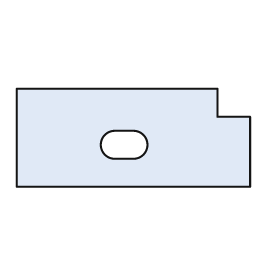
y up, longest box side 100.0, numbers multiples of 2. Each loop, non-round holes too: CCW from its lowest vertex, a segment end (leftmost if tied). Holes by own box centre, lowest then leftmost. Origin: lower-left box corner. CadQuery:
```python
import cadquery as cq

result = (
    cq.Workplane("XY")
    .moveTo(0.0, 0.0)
    .lineTo(100.0, 0.0)
    .lineTo(100.0, 30.0)
    .lineTo(86.0, 30.0)
    .lineTo(86.0, 42.0)
    .lineTo(0.0, 42.0)
    .close()
    .moveTo(42.0, 12.0)
    .lineTo(50.0, 12.0)
    .threePointArc((56.0, 18.0), (50.0, 24.0))
    .lineTo(42.0, 24.0)
    .threePointArc((36.0, 18.0), (42.0, 12.0))
    .close()
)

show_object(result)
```